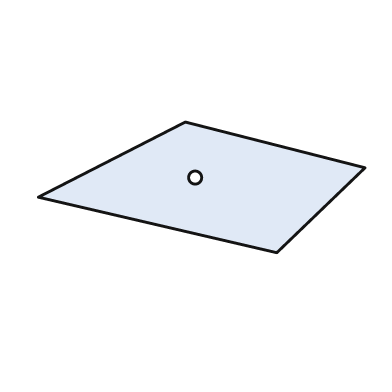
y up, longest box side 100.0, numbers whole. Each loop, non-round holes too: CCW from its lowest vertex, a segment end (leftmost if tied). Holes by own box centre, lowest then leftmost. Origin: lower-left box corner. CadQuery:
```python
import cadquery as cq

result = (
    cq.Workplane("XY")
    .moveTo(73.0, 0.0)
    .lineTo(100.0, 26.0)
    .lineTo(45.0, 40.0)
    .lineTo(0.0, 17.0)
    .close()
    .moveTo(48.0, 23.0)
    .circle(2.0)
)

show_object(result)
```